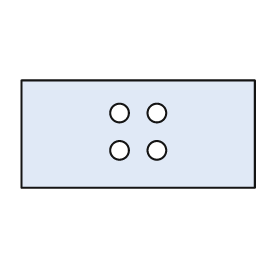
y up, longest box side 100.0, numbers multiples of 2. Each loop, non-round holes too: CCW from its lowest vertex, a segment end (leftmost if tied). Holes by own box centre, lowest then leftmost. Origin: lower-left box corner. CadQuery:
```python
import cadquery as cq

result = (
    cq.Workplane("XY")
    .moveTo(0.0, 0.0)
    .lineTo(100.0, 0.0)
    .lineTo(100.0, 46.0)
    .lineTo(0.0, 46.0)
    .close()
    .moveTo(42.0, 16.0)
    .circle(4.0)
    .moveTo(58.0, 16.0)
    .circle(4.0)
    .moveTo(42.0, 32.0)
    .circle(4.0)
    .moveTo(58.0, 32.0)
    .circle(4.0)
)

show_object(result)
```